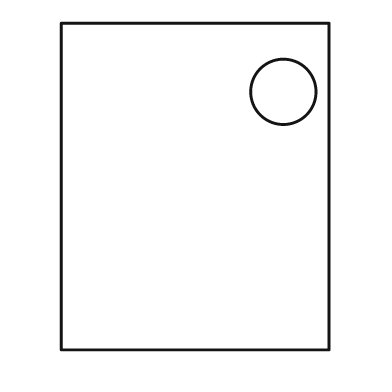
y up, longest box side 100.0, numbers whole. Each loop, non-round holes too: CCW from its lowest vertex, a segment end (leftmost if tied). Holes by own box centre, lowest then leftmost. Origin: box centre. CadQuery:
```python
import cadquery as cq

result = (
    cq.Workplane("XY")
    .moveTo(-41.0, -50.0)
    .lineTo(41.0, -50.0)
    .lineTo(41.0, 50.0)
    .lineTo(-41.0, 50.0)
    .close()
    .moveTo(27.0, 29.0)
    .circle(10.0)
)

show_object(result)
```